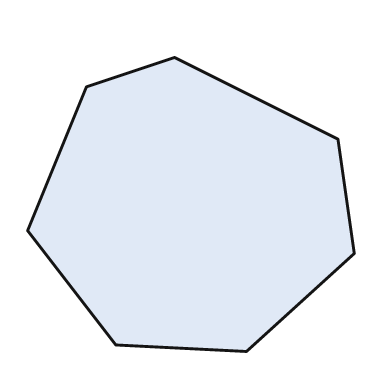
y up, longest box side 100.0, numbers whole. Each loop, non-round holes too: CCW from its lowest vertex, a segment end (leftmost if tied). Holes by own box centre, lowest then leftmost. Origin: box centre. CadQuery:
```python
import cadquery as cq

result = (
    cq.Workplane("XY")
    .moveTo(17.0, -45.0)
    .lineTo(50.0, -15.0)
    .lineTo(45.0, 20.0)
    .lineTo(-5.0, 45.0)
    .lineTo(-32.0, 36.0)
    .lineTo(-50.0, -8.0)
    .lineTo(-23.0, -43.0)
    .close()
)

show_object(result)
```